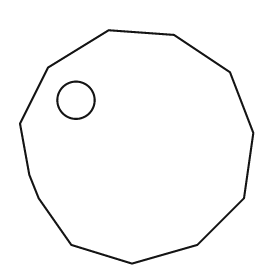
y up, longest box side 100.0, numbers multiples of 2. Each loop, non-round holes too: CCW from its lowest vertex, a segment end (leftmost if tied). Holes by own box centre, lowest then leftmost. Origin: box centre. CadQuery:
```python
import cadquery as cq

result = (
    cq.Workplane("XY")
    .moveTo(-2.0, -50.0)
    .lineTo(26.0, -42.0)
    .lineTo(46.0, -22.0)
    .lineTo(50.0, 6.0)
    .lineTo(40.0, 32.0)
    .lineTo(16.0, 48.0)
    .lineTo(-12.0, 50.0)
    .lineTo(-38.0, 34.0)
    .lineTo(-50.0, 10.0)
    .lineTo(-46.0, -12.0)
    .lineTo(-42.0, -22.0)
    .lineTo(-28.0, -42.0)
    .close()
    .moveTo(-26.0, 20.0)
    .circle(8.0)
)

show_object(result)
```